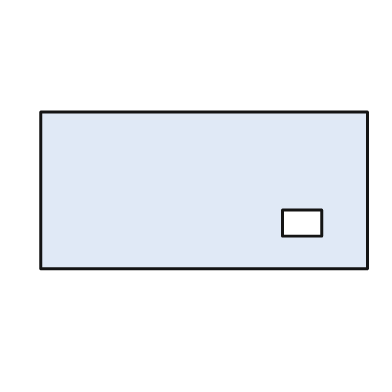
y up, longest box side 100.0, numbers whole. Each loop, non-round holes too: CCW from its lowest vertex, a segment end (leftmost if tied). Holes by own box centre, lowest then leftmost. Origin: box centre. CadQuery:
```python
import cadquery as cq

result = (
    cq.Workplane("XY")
    .moveTo(-50.0, -24.0)
    .lineTo(50.0, -24.0)
    .lineTo(50.0, 24.0)
    .lineTo(-50.0, 24.0)
    .close()
    .moveTo(24.0, -14.0)
    .lineTo(36.0, -14.0)
    .lineTo(36.0, -6.0)
    .lineTo(24.0, -6.0)
    .close()
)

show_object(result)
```